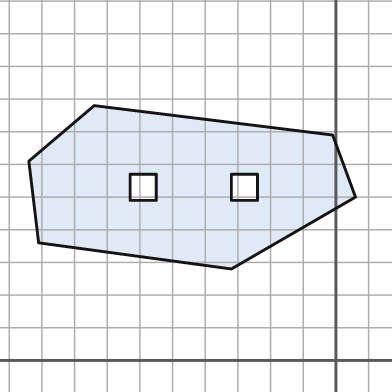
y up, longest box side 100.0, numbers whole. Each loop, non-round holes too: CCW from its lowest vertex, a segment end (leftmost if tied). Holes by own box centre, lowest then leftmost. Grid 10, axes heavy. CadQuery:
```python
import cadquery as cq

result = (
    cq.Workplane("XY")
    .moveTo(-32.0, 28.0)
    .lineTo(6.0, 50.0)
    .lineTo(-1.0, 69.0)
    .lineTo(-74.0, 78.0)
    .lineTo(-94.0, 61.0)
    .lineTo(-91.0, 36.0)
    .close()
    .moveTo(-63.0, 49.0)
    .lineTo(-55.0, 49.0)
    .lineTo(-55.0, 57.0)
    .lineTo(-63.0, 57.0)
    .close()
    .moveTo(-32.0, 49.0)
    .lineTo(-24.0, 49.0)
    .lineTo(-24.0, 57.0)
    .lineTo(-32.0, 57.0)
    .close()
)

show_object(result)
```